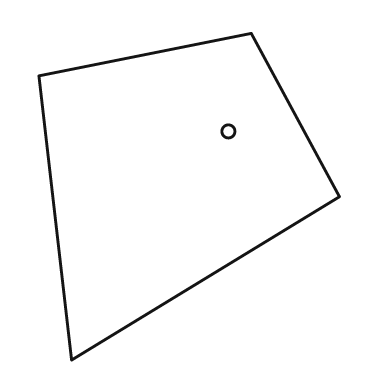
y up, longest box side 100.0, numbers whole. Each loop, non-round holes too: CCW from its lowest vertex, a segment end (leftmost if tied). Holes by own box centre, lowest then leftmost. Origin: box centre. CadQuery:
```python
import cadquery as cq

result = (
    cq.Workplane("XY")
    .moveTo(-36.0, -50.0)
    .lineTo(46.0, 0.0)
    .lineTo(19.0, 50.0)
    .lineTo(-46.0, 37.0)
    .close()
    .moveTo(12.0, 20.0)
    .circle(2.0)
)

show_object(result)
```